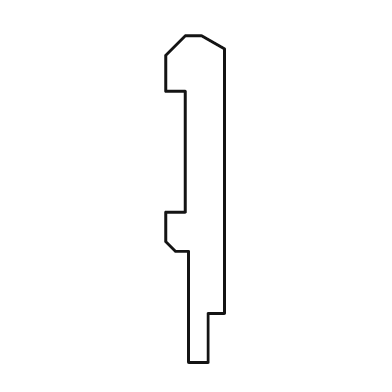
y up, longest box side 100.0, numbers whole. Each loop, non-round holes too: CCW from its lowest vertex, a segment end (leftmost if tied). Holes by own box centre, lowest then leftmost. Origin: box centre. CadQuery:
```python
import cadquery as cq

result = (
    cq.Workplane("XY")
    .moveTo(-2.0, -50.0)
    .lineTo(4.0, -50.0)
    .lineTo(4.0, -35.0)
    .lineTo(9.0, -35.0)
    .lineTo(9.0, 46.0)
    .lineTo(2.0, 50.0)
    .lineTo(-3.0, 50.0)
    .lineTo(-9.0, 44.0)
    .lineTo(-9.0, 33.0)
    .lineTo(-3.0, 33.0)
    .lineTo(-3.0, -4.0)
    .lineTo(-9.0, -4.0)
    .lineTo(-9.0, -13.0)
    .lineTo(-6.0, -16.0)
    .lineTo(-2.0, -16.0)
    .close()
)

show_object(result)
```